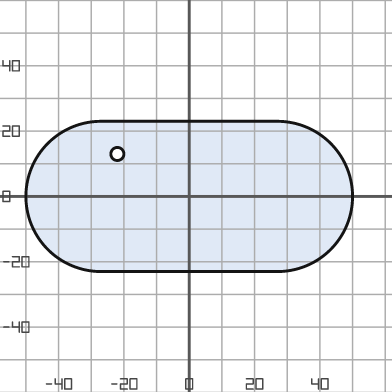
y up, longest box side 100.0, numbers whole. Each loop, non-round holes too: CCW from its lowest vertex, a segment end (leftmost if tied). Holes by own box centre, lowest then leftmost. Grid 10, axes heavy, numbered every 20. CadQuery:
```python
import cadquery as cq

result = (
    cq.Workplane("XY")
    .moveTo(-27.0, -23.0)
    .lineTo(27.0, -23.0)
    .threePointArc((50.0, 0.0), (27.0, 23.0))
    .lineTo(-27.0, 23.0)
    .threePointArc((-50.0, 0.0), (-27.0, -23.0))
    .close()
    .moveTo(-22.0, 13.0)
    .circle(2.0)
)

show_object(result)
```